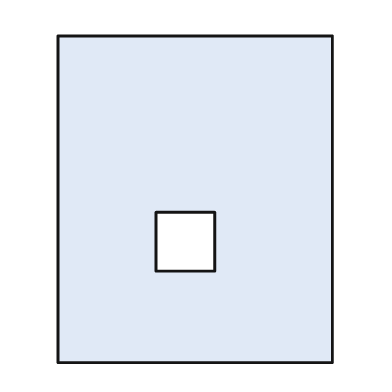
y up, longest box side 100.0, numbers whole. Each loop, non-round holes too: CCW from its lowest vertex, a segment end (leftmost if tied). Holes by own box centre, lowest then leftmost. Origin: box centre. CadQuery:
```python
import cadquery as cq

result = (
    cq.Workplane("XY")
    .moveTo(-42.0, -50.0)
    .lineTo(42.0, -50.0)
    .lineTo(42.0, 50.0)
    .lineTo(-42.0, 50.0)
    .close()
    .moveTo(-12.0, -22.0)
    .lineTo(6.0, -22.0)
    .lineTo(6.0, -4.0)
    .lineTo(-12.0, -4.0)
    .close()
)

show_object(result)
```